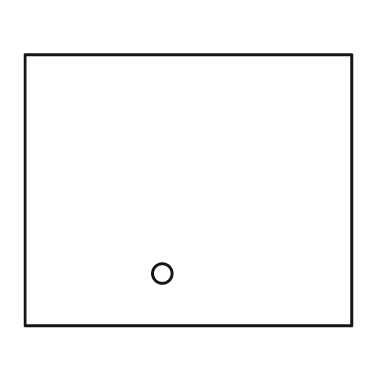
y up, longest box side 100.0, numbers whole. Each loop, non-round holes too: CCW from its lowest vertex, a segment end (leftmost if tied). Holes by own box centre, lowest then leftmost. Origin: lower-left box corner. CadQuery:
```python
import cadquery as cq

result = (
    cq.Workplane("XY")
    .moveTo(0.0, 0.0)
    .lineTo(100.0, 0.0)
    .lineTo(100.0, 83.0)
    .lineTo(0.0, 83.0)
    .close()
    .moveTo(42.0, 16.0)
    .circle(3.0)
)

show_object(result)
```